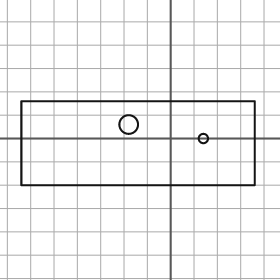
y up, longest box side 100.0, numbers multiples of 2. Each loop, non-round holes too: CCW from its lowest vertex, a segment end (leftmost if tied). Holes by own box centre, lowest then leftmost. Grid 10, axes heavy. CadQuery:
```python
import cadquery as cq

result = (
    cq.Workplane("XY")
    .moveTo(-64.0, -20.0)
    .lineTo(36.0, -20.0)
    .lineTo(36.0, 16.0)
    .lineTo(-64.0, 16.0)
    .close()
    .moveTo(14.0, 0.0)
    .circle(2.0)
    .moveTo(-18.0, 6.0)
    .circle(4.0)
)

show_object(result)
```